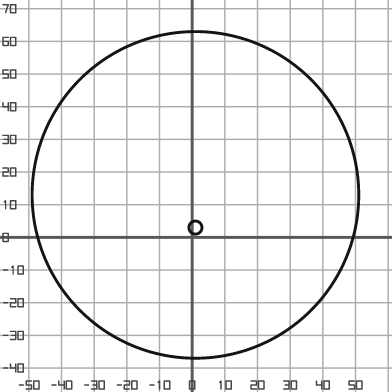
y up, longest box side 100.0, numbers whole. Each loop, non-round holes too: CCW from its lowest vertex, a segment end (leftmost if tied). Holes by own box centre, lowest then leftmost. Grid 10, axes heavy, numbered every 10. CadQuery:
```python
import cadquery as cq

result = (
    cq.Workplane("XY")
    .moveTo(1.0, 13.0)
    .circle(50.0)
    .moveTo(1.0, 3.0)
    .circle(2.0)
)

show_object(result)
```